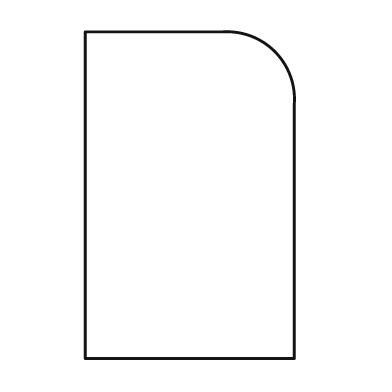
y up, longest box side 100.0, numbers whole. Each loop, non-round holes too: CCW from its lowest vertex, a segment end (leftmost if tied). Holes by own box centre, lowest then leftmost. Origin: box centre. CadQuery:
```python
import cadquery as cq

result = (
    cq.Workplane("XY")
    .moveTo(-32.0, -50.0)
    .lineTo(32.0, -50.0)
    .lineTo(32.0, 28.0)
    .threePointArc((26.0, 44.0), (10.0, 50.0))
    .lineTo(-32.0, 50.0)
    .close()
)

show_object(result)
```